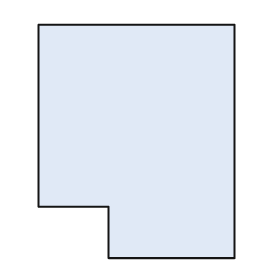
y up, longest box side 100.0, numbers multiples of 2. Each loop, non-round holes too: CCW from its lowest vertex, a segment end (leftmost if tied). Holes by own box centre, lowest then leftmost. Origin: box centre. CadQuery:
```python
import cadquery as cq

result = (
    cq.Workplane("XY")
    .moveTo(-12.0, -50.0)
    .lineTo(42.0, -50.0)
    .lineTo(42.0, 50.0)
    .lineTo(-42.0, 50.0)
    .lineTo(-42.0, -28.0)
    .lineTo(-12.0, -28.0)
    .close()
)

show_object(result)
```